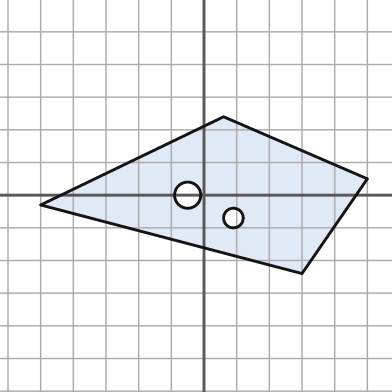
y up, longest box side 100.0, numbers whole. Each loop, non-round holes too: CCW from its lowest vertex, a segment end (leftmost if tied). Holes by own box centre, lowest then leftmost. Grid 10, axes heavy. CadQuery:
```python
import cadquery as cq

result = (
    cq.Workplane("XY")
    .moveTo(30.0, -24.0)
    .lineTo(50.0, 5.0)
    .lineTo(6.0, 24.0)
    .lineTo(-50.0, -3.0)
    .close()
    .moveTo(9.0, -7.0)
    .circle(3.0)
    .moveTo(-5.0, 0.0)
    .circle(4.0)
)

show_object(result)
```